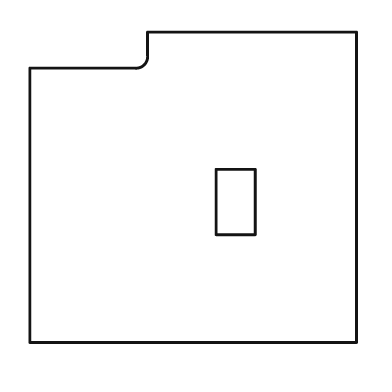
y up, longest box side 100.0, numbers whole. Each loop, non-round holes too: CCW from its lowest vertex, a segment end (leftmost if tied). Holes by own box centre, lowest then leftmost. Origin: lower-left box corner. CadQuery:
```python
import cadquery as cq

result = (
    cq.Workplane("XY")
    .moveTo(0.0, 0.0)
    .lineTo(100.0, 0.0)
    .lineTo(100.0, 95.0)
    .lineTo(36.0, 95.0)
    .lineTo(36.0, 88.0)
    .threePointArc((35.0, 85.0), (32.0, 84.0))
    .lineTo(0.0, 84.0)
    .close()
    .moveTo(57.0, 33.0)
    .lineTo(69.0, 33.0)
    .lineTo(69.0, 53.0)
    .lineTo(57.0, 53.0)
    .close()
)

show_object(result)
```